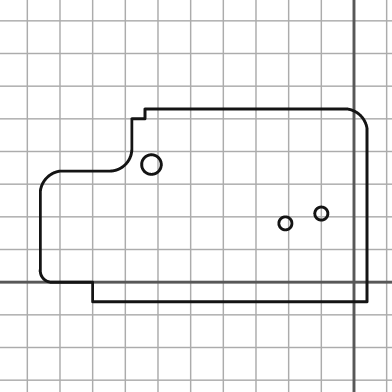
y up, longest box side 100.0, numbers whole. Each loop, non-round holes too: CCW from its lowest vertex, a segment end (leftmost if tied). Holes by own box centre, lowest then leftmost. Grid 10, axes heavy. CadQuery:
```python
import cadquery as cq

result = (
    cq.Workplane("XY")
    .moveTo(-80.0, -6.0)
    .lineTo(4.0, -6.0)
    .lineTo(4.0, 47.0)
    .threePointArc((2.0, 51.0), (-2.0, 53.0))
    .lineTo(-64.0, 53.0)
    .lineTo(-64.0, 50.0)
    .lineTo(-68.0, 50.0)
    .lineTo(-68.0, 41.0)
    .threePointArc((-70.0, 36.0), (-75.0, 34.0))
    .lineTo(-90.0, 34.0)
    .threePointArc((-94.0, 32.0), (-96.0, 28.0))
    .lineTo(-96.0, 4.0)
    .threePointArc((-95.0, 1.0), (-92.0, 0.0))
    .lineTo(-80.0, 0.0)
    .close()
    .moveTo(-21.0, 18.0)
    .circle(2.0)
    .moveTo(-10.0, 21.0)
    .circle(2.0)
    .moveTo(-62.0, 36.0)
    .circle(3.0)
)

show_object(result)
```